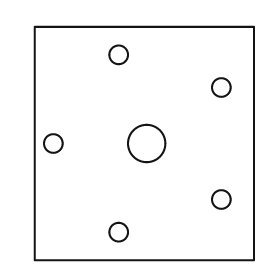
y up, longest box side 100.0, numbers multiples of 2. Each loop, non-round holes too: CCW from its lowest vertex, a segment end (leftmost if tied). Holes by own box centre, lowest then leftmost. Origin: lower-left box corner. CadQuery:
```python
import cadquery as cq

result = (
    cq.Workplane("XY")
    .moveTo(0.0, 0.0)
    .lineTo(94.0, 0.0)
    .lineTo(94.0, 100.0)
    .lineTo(0.0, 100.0)
    .close()
    .moveTo(36.0, 12.0)
    .circle(4.0)
    .moveTo(80.0, 26.0)
    .circle(4.0)
    .moveTo(8.0, 50.0)
    .circle(4.0)
    .moveTo(48.0, 50.0)
    .circle(8.0)
    .moveTo(80.0, 74.0)
    .circle(4.0)
    .moveTo(36.0, 88.0)
    .circle(4.0)
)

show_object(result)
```